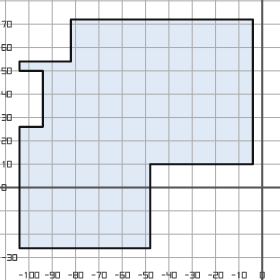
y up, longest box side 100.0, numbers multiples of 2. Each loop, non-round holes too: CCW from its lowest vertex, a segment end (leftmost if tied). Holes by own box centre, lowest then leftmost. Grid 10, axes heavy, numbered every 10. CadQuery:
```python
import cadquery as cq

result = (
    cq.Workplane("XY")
    .moveTo(-104.0, -26.0)
    .lineTo(-48.0, -26.0)
    .lineTo(-48.0, 10.0)
    .lineTo(-4.0, 10.0)
    .lineTo(-4.0, 72.0)
    .lineTo(-82.0, 72.0)
    .lineTo(-82.0, 54.0)
    .lineTo(-104.0, 54.0)
    .lineTo(-104.0, 50.0)
    .lineTo(-94.0, 50.0)
    .lineTo(-94.0, 26.0)
    .lineTo(-104.0, 26.0)
    .close()
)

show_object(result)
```